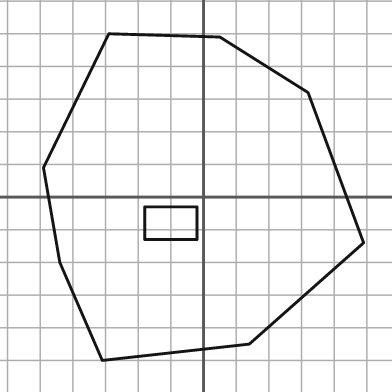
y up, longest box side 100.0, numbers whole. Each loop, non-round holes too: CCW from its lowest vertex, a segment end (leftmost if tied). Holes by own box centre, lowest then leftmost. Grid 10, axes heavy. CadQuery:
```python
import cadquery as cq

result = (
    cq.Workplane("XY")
    .moveTo(-31.0, -50.0)
    .lineTo(14.0, -45.0)
    .lineTo(49.0, -14.0)
    .lineTo(32.0, 32.0)
    .lineTo(5.0, 49.0)
    .lineTo(-29.0, 50.0)
    .lineTo(-49.0, 9.0)
    .lineTo(-44.0, -20.0)
    .close()
    .moveTo(-18.0, -13.0)
    .lineTo(-2.0, -13.0)
    .lineTo(-2.0, -3.0)
    .lineTo(-18.0, -3.0)
    .close()
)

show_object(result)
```